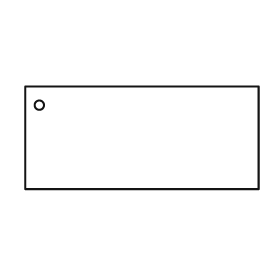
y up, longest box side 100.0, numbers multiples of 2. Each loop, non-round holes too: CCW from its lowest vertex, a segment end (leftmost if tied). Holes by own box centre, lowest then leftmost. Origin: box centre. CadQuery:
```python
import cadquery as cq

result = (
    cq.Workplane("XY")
    .moveTo(-50.0, -22.0)
    .lineTo(50.0, -22.0)
    .lineTo(50.0, 22.0)
    .lineTo(-50.0, 22.0)
    .close()
    .moveTo(-44.0, 14.0)
    .circle(2.0)
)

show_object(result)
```